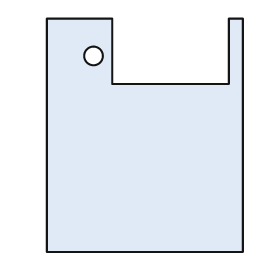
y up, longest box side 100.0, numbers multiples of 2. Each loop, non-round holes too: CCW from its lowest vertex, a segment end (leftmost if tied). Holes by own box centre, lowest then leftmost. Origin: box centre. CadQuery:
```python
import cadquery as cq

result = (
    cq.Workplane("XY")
    .moveTo(-42.0, -50.0)
    .lineTo(42.0, -50.0)
    .lineTo(42.0, 50.0)
    .lineTo(36.0, 50.0)
    .lineTo(36.0, 22.0)
    .lineTo(-14.0, 22.0)
    .lineTo(-14.0, 50.0)
    .lineTo(-42.0, 50.0)
    .close()
    .moveTo(-22.0, 34.0)
    .circle(4.0)
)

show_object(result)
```